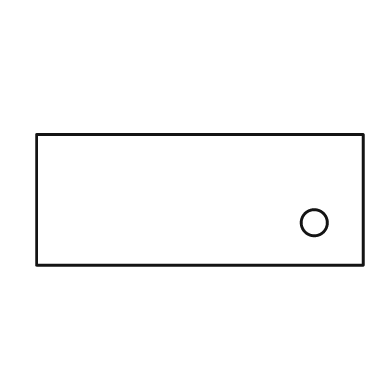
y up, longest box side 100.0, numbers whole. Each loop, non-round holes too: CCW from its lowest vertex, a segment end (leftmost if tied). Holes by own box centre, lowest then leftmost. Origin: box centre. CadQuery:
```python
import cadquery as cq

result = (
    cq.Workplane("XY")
    .moveTo(-50.0, -20.0)
    .lineTo(50.0, -20.0)
    .lineTo(50.0, 20.0)
    .lineTo(-50.0, 20.0)
    .close()
    .moveTo(35.0, -7.0)
    .circle(4.0)
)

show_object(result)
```